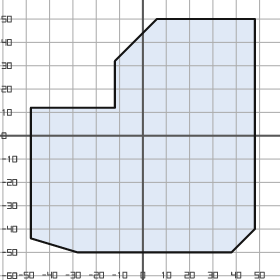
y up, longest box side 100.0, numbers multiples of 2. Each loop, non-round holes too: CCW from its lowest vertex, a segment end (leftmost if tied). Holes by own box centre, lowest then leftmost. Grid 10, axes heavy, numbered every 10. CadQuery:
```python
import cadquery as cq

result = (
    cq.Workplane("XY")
    .moveTo(-28.0, -50.0)
    .lineTo(38.0, -50.0)
    .lineTo(48.0, -40.0)
    .lineTo(48.0, 50.0)
    .lineTo(6.0, 50.0)
    .lineTo(-12.0, 32.0)
    .lineTo(-12.0, 12.0)
    .lineTo(-48.0, 12.0)
    .lineTo(-48.0, -44.0)
    .close()
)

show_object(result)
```